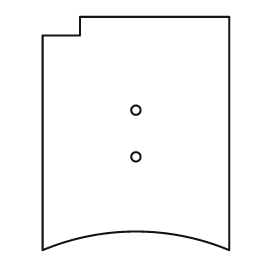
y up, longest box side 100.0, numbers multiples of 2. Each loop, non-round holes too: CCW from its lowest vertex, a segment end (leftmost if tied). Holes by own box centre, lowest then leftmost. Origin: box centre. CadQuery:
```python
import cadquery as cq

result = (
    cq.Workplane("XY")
    .moveTo(-40.0, -50.0)
    .threePointArc((0.0, -42.0), (40.0, -50.0))
    .lineTo(40.0, 50.0)
    .lineTo(-24.0, 50.0)
    .lineTo(-24.0, 42.0)
    .lineTo(-40.0, 42.0)
    .close()
    .moveTo(0.0, -10.0)
    .circle(2.0)
    .moveTo(0.0, 10.0)
    .circle(2.0)
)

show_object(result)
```